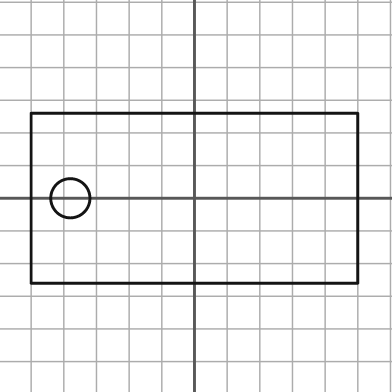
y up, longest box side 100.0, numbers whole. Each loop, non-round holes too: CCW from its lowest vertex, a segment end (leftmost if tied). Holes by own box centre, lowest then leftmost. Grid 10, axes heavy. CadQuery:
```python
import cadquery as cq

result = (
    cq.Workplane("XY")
    .moveTo(-50.0, -26.0)
    .lineTo(50.0, -26.0)
    .lineTo(50.0, 26.0)
    .lineTo(-50.0, 26.0)
    .close()
    .moveTo(-38.0, 0.0)
    .circle(6.0)
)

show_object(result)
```